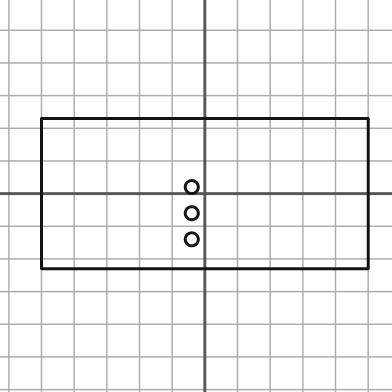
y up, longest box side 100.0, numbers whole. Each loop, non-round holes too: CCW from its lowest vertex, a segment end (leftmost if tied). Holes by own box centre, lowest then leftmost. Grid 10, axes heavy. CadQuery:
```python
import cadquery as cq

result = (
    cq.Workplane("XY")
    .moveTo(-50.0, -23.0)
    .lineTo(50.0, -23.0)
    .lineTo(50.0, 23.0)
    .lineTo(-50.0, 23.0)
    .close()
    .moveTo(-4.0, -14.0)
    .circle(2.0)
    .moveTo(-4.0, -6.0)
    .circle(2.0)
    .moveTo(-4.0, 2.0)
    .circle(2.0)
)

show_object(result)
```